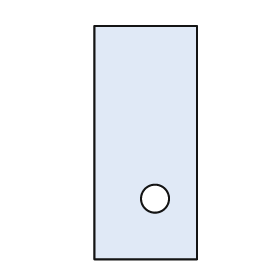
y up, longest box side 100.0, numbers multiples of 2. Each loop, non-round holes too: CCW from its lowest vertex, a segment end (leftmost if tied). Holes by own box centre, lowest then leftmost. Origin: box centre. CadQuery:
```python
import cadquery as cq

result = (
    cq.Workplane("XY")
    .moveTo(-22.0, -50.0)
    .lineTo(22.0, -50.0)
    .lineTo(22.0, 50.0)
    .lineTo(-22.0, 50.0)
    .close()
    .moveTo(4.0, -24.0)
    .circle(6.0)
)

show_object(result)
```